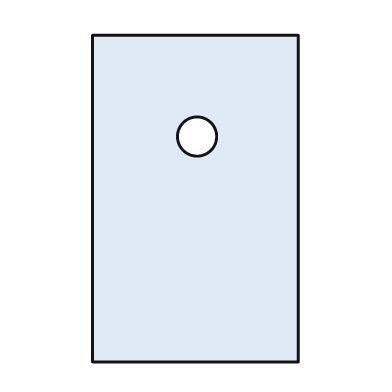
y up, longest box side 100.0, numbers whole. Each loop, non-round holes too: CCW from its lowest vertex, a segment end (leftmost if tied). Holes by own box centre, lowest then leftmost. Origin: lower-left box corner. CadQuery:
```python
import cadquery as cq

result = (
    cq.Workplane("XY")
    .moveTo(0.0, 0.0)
    .lineTo(63.0, 0.0)
    .lineTo(63.0, 100.0)
    .lineTo(0.0, 100.0)
    .close()
    .moveTo(32.0, 69.0)
    .circle(6.0)
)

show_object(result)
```